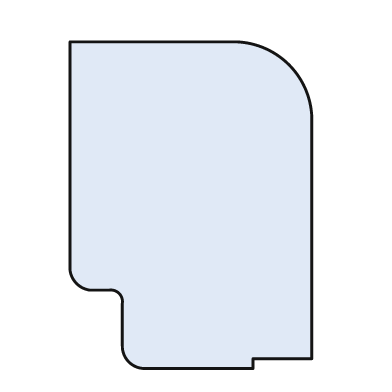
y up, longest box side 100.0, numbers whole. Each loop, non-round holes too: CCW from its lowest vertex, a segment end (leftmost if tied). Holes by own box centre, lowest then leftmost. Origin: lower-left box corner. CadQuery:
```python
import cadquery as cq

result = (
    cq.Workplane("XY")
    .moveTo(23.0, 0.0)
    .lineTo(56.0, 0.0)
    .lineTo(56.0, 3.0)
    .lineTo(74.0, 3.0)
    .lineTo(74.0, 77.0)
    .threePointArc((67.0, 93.0), (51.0, 100.0))
    .lineTo(0.0, 100.0)
    .lineTo(0.0, 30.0)
    .threePointArc((2.0, 26.0), (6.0, 24.0))
    .lineTo(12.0, 24.0)
    .threePointArc((15.0, 23.0), (16.0, 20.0))
    .lineTo(16.0, 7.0)
    .threePointArc((18.0, 2.0), (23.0, 0.0))
    .close()
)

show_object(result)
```